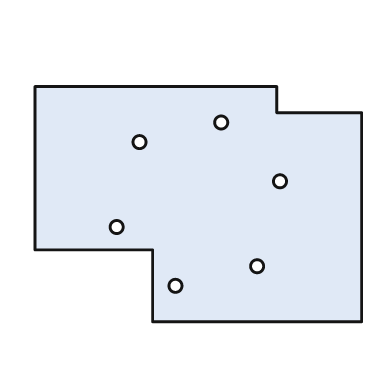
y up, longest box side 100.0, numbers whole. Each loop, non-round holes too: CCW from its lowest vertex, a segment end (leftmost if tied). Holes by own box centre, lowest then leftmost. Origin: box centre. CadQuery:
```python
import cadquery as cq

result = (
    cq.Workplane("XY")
    .moveTo(-14.0, -36.0)
    .lineTo(50.0, -36.0)
    .lineTo(50.0, 28.0)
    .lineTo(24.0, 28.0)
    .lineTo(24.0, 36.0)
    .lineTo(-50.0, 36.0)
    .lineTo(-50.0, -14.0)
    .lineTo(-14.0, -14.0)
    .close()
    .moveTo(-7.0, -25.0)
    .circle(2.0)
    .moveTo(18.0, -19.0)
    .circle(2.0)
    .moveTo(-25.0, -7.0)
    .circle(2.0)
    .moveTo(25.0, 7.0)
    .circle(2.0)
    .moveTo(-18.0, 19.0)
    .circle(2.0)
    .moveTo(7.0, 25.0)
    .circle(2.0)
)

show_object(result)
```